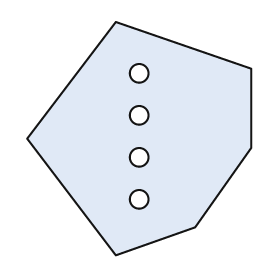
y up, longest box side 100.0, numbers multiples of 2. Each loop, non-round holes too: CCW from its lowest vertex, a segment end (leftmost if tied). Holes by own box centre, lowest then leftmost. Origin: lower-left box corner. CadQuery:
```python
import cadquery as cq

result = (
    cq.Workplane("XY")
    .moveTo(38.0, 0.0)
    .lineTo(72.0, 12.0)
    .lineTo(96.0, 46.0)
    .lineTo(96.0, 80.0)
    .lineTo(38.0, 100.0)
    .lineTo(0.0, 50.0)
    .close()
    .moveTo(48.0, 24.0)
    .circle(4.0)
    .moveTo(48.0, 42.0)
    .circle(4.0)
    .moveTo(48.0, 60.0)
    .circle(4.0)
    .moveTo(48.0, 78.0)
    .circle(4.0)
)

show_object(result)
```